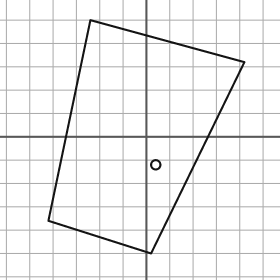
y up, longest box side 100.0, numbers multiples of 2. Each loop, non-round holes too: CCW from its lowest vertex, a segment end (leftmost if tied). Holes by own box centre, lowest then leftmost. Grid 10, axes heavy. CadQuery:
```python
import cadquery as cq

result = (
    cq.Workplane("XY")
    .moveTo(2.0, -50.0)
    .lineTo(42.0, 32.0)
    .lineTo(-24.0, 50.0)
    .lineTo(-42.0, -36.0)
    .close()
    .moveTo(4.0, -12.0)
    .circle(2.0)
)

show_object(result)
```